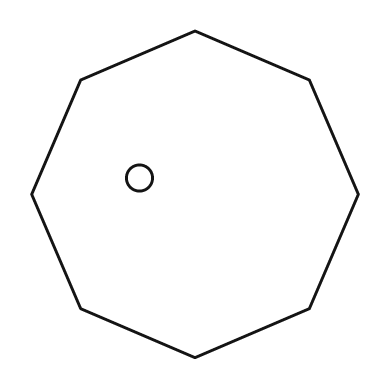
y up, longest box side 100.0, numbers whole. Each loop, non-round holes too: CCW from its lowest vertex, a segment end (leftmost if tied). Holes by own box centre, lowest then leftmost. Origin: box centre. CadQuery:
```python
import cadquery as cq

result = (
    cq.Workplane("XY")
    .moveTo(0.0, -50.0)
    .lineTo(35.0, -35.0)
    .lineTo(50.0, 0.0)
    .lineTo(35.0, 35.0)
    .lineTo(0.0, 50.0)
    .lineTo(-35.0, 35.0)
    .lineTo(-50.0, 0.0)
    .lineTo(-35.0, -35.0)
    .close()
    .moveTo(-17.0, 5.0)
    .circle(4.0)
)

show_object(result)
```